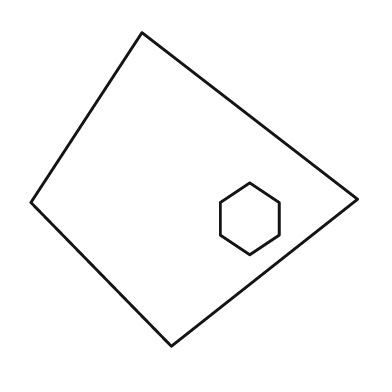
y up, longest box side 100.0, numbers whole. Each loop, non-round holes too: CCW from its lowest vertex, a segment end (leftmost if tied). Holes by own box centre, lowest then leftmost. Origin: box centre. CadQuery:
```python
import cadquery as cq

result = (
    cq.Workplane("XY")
    .moveTo(-7.0, -48.0)
    .lineTo(50.0, -3.0)
    .lineTo(-16.0, 48.0)
    .lineTo(-50.0, -4.0)
    .close()
    .moveTo(17.0, -20.0)
    .lineTo(26.0, -14.0)
    .lineTo(26.0, -4.0)
    .lineTo(17.0, 2.0)
    .lineTo(8.0, -4.0)
    .lineTo(8.0, -14.0)
    .close()
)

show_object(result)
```